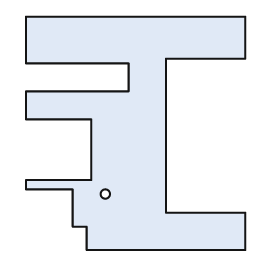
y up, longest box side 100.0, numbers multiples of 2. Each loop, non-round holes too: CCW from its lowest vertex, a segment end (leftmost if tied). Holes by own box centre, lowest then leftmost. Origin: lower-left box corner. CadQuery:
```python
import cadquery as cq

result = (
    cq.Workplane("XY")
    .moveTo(26.0, 0.0)
    .lineTo(94.0, 0.0)
    .lineTo(94.0, 16.0)
    .lineTo(60.0, 16.0)
    .lineTo(60.0, 82.0)
    .lineTo(94.0, 82.0)
    .lineTo(94.0, 100.0)
    .lineTo(0.0, 100.0)
    .lineTo(0.0, 80.0)
    .lineTo(44.0, 80.0)
    .lineTo(44.0, 68.0)
    .lineTo(0.0, 68.0)
    .lineTo(0.0, 56.0)
    .lineTo(28.0, 56.0)
    .lineTo(28.0, 30.0)
    .lineTo(0.0, 30.0)
    .lineTo(0.0, 26.0)
    .lineTo(20.0, 26.0)
    .lineTo(20.0, 10.0)
    .lineTo(26.0, 10.0)
    .close()
    .moveTo(34.0, 24.0)
    .circle(2.0)
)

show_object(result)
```